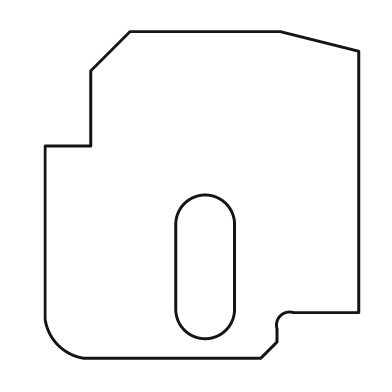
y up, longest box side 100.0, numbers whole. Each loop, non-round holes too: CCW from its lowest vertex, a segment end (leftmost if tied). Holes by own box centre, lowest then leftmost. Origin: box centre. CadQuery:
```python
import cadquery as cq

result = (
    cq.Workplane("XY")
    .moveTo(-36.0, -50.0)
    .lineTo(18.0, -50.0)
    .lineTo(23.0, -45.0)
    .lineTo(23.0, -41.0)
    .threePointArc((24.0, -37.0), (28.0, -36.0))
    .lineTo(48.0, -36.0)
    .lineTo(48.0, 44.0)
    .lineTo(24.0, 50.0)
    .lineTo(-22.0, 50.0)
    .lineTo(-34.0, 38.0)
    .lineTo(-34.0, 15.0)
    .lineTo(-48.0, 15.0)
    .lineTo(-48.0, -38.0)
    .threePointArc((-44.0, -46.0), (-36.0, -50.0))
    .close()
    .moveTo(-8.0, -35.0)
    .threePointArc((1.0, -44.0), (10.0, -35.0))
    .lineTo(10.0, -9.0)
    .threePointArc((1.0, 0.0), (-8.0, -9.0))
    .close()
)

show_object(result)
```